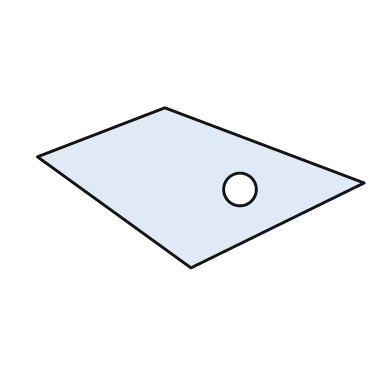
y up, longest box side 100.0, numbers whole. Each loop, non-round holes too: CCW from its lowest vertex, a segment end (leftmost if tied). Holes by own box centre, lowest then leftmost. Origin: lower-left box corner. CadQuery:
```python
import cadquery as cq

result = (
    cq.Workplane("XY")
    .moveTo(47.0, 0.0)
    .lineTo(100.0, 26.0)
    .lineTo(39.0, 49.0)
    .lineTo(0.0, 34.0)
    .close()
    .moveTo(62.0, 24.0)
    .circle(5.0)
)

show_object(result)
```